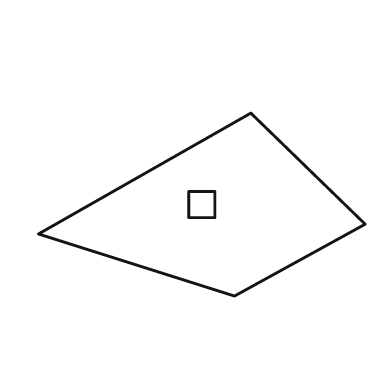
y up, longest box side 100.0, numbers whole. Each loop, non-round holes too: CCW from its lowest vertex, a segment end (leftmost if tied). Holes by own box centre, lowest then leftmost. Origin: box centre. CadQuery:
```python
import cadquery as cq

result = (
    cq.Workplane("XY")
    .moveTo(10.0, -28.0)
    .lineTo(50.0, -6.0)
    .lineTo(15.0, 28.0)
    .lineTo(-50.0, -9.0)
    .close()
    .moveTo(-4.0, -4.0)
    .lineTo(4.0, -4.0)
    .lineTo(4.0, 4.0)
    .lineTo(-4.0, 4.0)
    .close()
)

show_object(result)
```